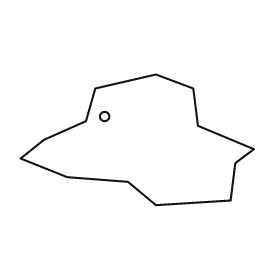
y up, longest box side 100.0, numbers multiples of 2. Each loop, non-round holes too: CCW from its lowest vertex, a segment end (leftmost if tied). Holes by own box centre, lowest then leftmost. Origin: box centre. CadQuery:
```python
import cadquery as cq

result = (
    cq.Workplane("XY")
    .moveTo(8.0, -28.0)
    .lineTo(40.0, -26.0)
    .lineTo(42.0, -10.0)
    .lineTo(50.0, -4.0)
    .lineTo(26.0, 6.0)
    .lineTo(24.0, 22.0)
    .lineTo(8.0, 28.0)
    .lineTo(-18.0, 22.0)
    .lineTo(-22.0, 8.0)
    .lineTo(-40.0, 0.0)
    .lineTo(-50.0, -8.0)
    .lineTo(-30.0, -16.0)
    .lineTo(-4.0, -18.0)
    .close()
    .moveTo(-14.0, 10.0)
    .circle(2.0)
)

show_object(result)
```